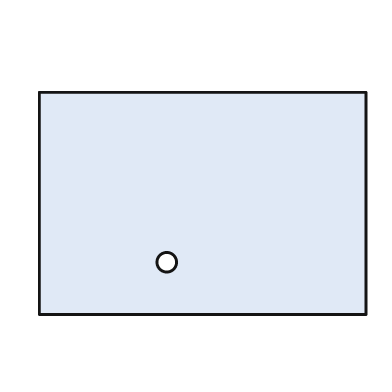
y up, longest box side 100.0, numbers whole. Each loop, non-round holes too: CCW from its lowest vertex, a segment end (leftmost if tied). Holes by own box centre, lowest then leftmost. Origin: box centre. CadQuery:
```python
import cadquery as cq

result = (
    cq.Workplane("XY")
    .moveTo(-50.0, -34.0)
    .lineTo(50.0, -34.0)
    .lineTo(50.0, 34.0)
    .lineTo(-50.0, 34.0)
    .close()
    .moveTo(-11.0, -18.0)
    .circle(3.0)
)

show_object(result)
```